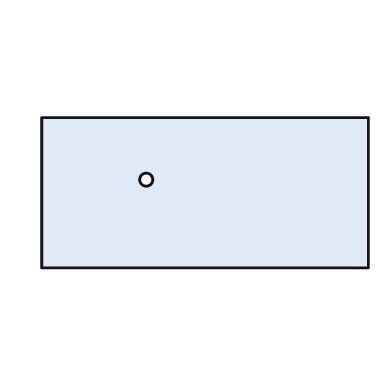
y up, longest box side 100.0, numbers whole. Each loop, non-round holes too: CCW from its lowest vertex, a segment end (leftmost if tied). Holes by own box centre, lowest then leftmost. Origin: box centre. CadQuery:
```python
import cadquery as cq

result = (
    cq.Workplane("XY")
    .moveTo(-50.0, -23.0)
    .lineTo(50.0, -23.0)
    .lineTo(50.0, 23.0)
    .lineTo(-50.0, 23.0)
    .close()
    .moveTo(-18.0, 4.0)
    .circle(2.0)
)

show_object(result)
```